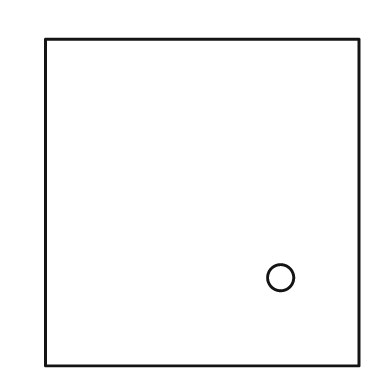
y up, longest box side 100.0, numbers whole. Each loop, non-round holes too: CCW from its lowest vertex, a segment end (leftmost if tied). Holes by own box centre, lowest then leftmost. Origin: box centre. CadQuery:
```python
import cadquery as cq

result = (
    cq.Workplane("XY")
    .moveTo(-48.0, -50.0)
    .lineTo(48.0, -50.0)
    .lineTo(48.0, 50.0)
    .lineTo(-48.0, 50.0)
    .close()
    .moveTo(24.0, -23.0)
    .circle(4.0)
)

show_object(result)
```